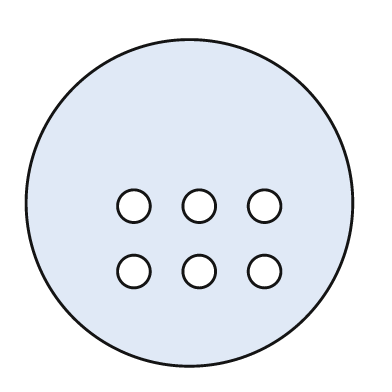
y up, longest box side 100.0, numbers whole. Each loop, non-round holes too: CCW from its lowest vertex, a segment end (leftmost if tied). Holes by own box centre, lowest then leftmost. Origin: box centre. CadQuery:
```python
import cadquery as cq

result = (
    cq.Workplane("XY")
    .moveTo(0.0, 0.0)
    .circle(50.0)
    .moveTo(-17.0, -21.0)
    .circle(5.0)
    .moveTo(3.0, -21.0)
    .circle(5.0)
    .moveTo(23.0, -21.0)
    .circle(5.0)
    .moveTo(-17.0, -1.0)
    .circle(5.0)
    .moveTo(3.0, -1.0)
    .circle(5.0)
    .moveTo(23.0, -1.0)
    .circle(5.0)
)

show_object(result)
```